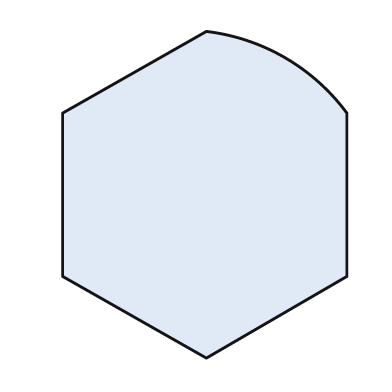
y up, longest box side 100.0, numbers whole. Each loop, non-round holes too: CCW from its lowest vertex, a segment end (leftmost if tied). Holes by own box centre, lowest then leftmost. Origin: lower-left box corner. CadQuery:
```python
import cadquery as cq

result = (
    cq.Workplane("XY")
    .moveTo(44.0, 0.0)
    .lineTo(87.0, 25.0)
    .lineTo(87.0, 75.0)
    .threePointArc((68.0, 92.0), (44.0, 100.0))
    .lineTo(0.0, 75.0)
    .lineTo(0.0, 25.0)
    .close()
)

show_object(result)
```